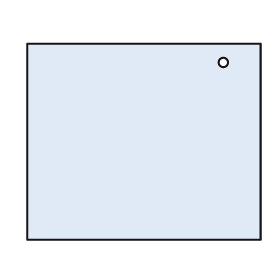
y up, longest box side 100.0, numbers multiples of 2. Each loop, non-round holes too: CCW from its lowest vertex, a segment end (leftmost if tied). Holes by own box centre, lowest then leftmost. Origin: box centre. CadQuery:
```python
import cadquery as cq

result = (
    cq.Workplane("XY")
    .moveTo(-50.0, -42.0)
    .lineTo(50.0, -42.0)
    .lineTo(50.0, 42.0)
    .lineTo(-50.0, 42.0)
    .close()
    .moveTo(34.0, 34.0)
    .circle(2.0)
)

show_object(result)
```